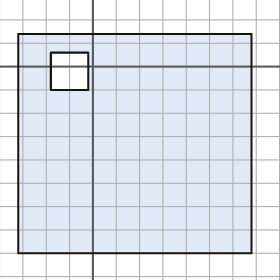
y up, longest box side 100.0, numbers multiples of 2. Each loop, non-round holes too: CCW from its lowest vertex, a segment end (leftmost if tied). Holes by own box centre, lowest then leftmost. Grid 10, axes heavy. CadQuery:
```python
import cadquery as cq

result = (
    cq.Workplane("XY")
    .moveTo(-32.0, -80.0)
    .lineTo(68.0, -80.0)
    .lineTo(68.0, 14.0)
    .lineTo(-32.0, 14.0)
    .close()
    .moveTo(-18.0, -10.0)
    .lineTo(-2.0, -10.0)
    .lineTo(-2.0, 6.0)
    .lineTo(-18.0, 6.0)
    .close()
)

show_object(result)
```